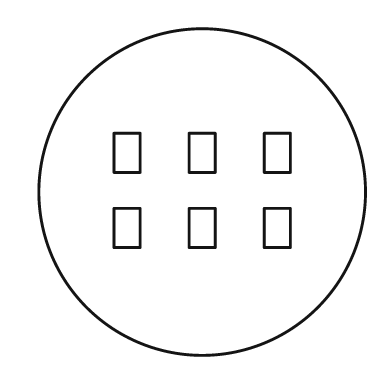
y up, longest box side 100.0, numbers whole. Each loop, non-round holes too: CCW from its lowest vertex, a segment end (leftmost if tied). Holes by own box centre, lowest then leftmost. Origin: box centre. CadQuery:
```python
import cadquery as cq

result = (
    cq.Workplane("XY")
    .moveTo(0.0, 0.0)
    .circle(50.0)
    .moveTo(-27.0, -17.0)
    .lineTo(-19.0, -17.0)
    .lineTo(-19.0, -5.0)
    .lineTo(-27.0, -5.0)
    .close()
    .moveTo(-4.0, -17.0)
    .lineTo(4.0, -17.0)
    .lineTo(4.0, -5.0)
    .lineTo(-4.0, -5.0)
    .close()
    .moveTo(19.0, -17.0)
    .lineTo(27.0, -17.0)
    .lineTo(27.0, -5.0)
    .lineTo(19.0, -5.0)
    .close()
    .moveTo(-27.0, 6.0)
    .lineTo(-19.0, 6.0)
    .lineTo(-19.0, 18.0)
    .lineTo(-27.0, 18.0)
    .close()
    .moveTo(-4.0, 6.0)
    .lineTo(4.0, 6.0)
    .lineTo(4.0, 18.0)
    .lineTo(-4.0, 18.0)
    .close()
    .moveTo(19.0, 6.0)
    .lineTo(27.0, 6.0)
    .lineTo(27.0, 18.0)
    .lineTo(19.0, 18.0)
    .close()
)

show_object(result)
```